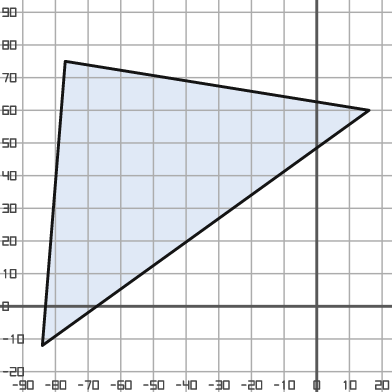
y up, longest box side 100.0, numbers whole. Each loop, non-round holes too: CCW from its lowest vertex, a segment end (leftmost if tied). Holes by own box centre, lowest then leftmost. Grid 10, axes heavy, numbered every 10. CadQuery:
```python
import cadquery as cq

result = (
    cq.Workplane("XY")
    .moveTo(-84.0, -12.0)
    .lineTo(16.0, 60.0)
    .lineTo(-77.0, 75.0)
    .close()
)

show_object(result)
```